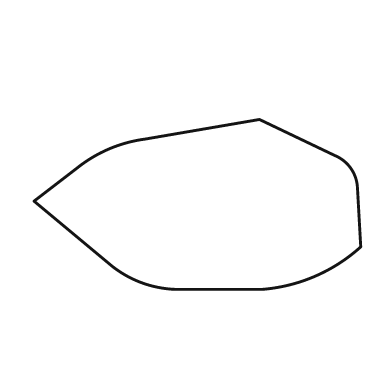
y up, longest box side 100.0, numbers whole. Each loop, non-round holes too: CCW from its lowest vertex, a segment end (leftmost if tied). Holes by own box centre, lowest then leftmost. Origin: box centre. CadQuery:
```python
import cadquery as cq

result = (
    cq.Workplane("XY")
    .moveTo(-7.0, -26.0)
    .lineTo(20.0, -26.0)
    .threePointArc((36.0, -22.0), (50.0, -13.0))
    .lineTo(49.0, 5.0)
    .threePointArc((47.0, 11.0), (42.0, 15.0))
    .lineTo(19.0, 26.0)
    .lineTo(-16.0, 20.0)
    .threePointArc((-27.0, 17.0), (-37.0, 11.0))
    .lineTo(-50.0, 1.0)
    .lineTo(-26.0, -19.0)
    .threePointArc((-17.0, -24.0), (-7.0, -26.0))
    .close()
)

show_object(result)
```